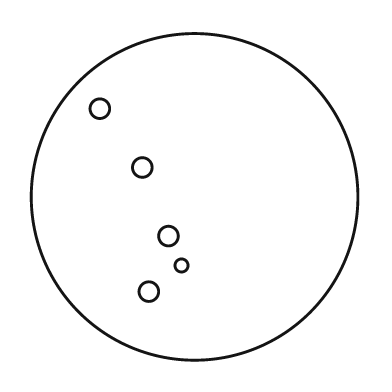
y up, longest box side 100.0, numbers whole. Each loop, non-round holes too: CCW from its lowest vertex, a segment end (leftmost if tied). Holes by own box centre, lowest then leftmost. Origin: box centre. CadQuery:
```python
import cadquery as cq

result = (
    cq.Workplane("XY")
    .moveTo(0.0, 0.0)
    .circle(50.0)
    .moveTo(-14.0, -29.0)
    .circle(3.0)
    .moveTo(-4.0, -21.0)
    .circle(2.0)
    .moveTo(-8.0, -12.0)
    .circle(3.0)
    .moveTo(-16.0, 9.0)
    .circle(3.0)
    .moveTo(-29.0, 27.0)
    .circle(3.0)
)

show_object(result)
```